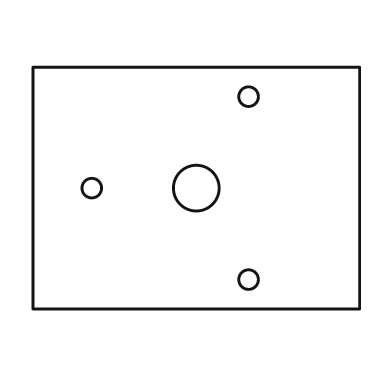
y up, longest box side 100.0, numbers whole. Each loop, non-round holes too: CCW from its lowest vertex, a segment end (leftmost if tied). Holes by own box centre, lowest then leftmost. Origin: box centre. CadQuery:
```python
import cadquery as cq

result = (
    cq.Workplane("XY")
    .moveTo(-50.0, -37.0)
    .lineTo(50.0, -37.0)
    .lineTo(50.0, 37.0)
    .lineTo(-50.0, 37.0)
    .close()
    .moveTo(16.0, -28.0)
    .circle(3.0)
    .moveTo(-32.0, 0.0)
    .circle(3.0)
    .moveTo(0.0, 0.0)
    .circle(7.0)
    .moveTo(16.0, 28.0)
    .circle(3.0)
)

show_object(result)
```